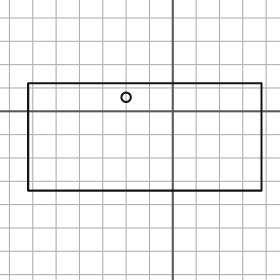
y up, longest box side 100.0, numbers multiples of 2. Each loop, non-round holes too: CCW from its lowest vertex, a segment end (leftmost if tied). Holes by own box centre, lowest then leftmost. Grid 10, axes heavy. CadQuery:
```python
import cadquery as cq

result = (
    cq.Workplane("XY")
    .moveTo(-62.0, -34.0)
    .lineTo(38.0, -34.0)
    .lineTo(38.0, 12.0)
    .lineTo(-62.0, 12.0)
    .close()
    .moveTo(-20.0, 6.0)
    .circle(2.0)
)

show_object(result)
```